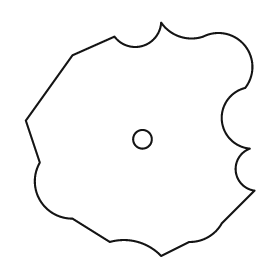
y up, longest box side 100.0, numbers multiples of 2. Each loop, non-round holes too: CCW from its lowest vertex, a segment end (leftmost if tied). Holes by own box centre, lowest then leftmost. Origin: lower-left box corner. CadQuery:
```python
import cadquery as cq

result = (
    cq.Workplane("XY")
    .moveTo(58.0, 0.0)
    .lineTo(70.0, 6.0)
    .threePointArc((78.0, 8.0), (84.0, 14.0))
    .lineTo(98.0, 28.0)
    .threePointArc((90.0, 36.0), (96.0, 46.0))
    .threePointArc((84.0, 58.0), (94.0, 72.0))
    .threePointArc((94.0, 90.0), (76.0, 94.0))
    .threePointArc((66.0, 94.0), (58.0, 100.0))
    .threePointArc((50.0, 90.0), (38.0, 94.0))
    .lineTo(20.0, 86.0)
    .lineTo(0.0, 58.0)
    .lineTo(6.0, 40.0)
    .threePointArc((6.0, 24.0), (20.0, 16.0))
    .lineTo(36.0, 6.0)
    .threePointArc((48.0, 6.0), (58.0, 0.0))
    .close()
    .moveTo(50.0, 50.0)
    .circle(4.0)
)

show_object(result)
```